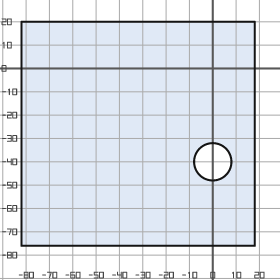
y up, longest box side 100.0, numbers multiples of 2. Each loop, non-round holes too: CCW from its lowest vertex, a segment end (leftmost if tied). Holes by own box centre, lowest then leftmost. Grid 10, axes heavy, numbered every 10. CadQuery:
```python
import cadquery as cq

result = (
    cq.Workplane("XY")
    .moveTo(-82.0, -76.0)
    .lineTo(18.0, -76.0)
    .lineTo(18.0, 20.0)
    .lineTo(-82.0, 20.0)
    .close()
    .moveTo(0.0, -40.0)
    .circle(8.0)
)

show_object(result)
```